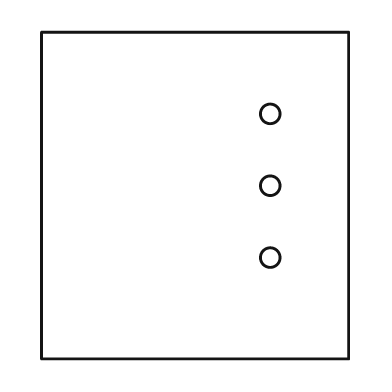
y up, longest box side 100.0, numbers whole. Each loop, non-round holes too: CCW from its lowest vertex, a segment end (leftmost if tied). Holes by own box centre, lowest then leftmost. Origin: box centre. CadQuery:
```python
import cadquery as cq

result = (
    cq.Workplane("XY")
    .moveTo(-47.0, -50.0)
    .lineTo(47.0, -50.0)
    .lineTo(47.0, 50.0)
    .lineTo(-47.0, 50.0)
    .close()
    .moveTo(23.0, -19.0)
    .circle(3.0)
    .moveTo(23.0, 3.0)
    .circle(3.0)
    .moveTo(23.0, 25.0)
    .circle(3.0)
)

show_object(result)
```